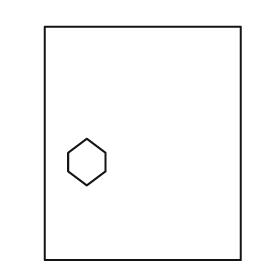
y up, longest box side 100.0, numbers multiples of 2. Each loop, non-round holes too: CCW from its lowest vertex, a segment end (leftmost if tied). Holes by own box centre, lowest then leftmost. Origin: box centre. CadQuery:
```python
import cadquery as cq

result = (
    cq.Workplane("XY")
    .moveTo(-42.0, -50.0)
    .lineTo(42.0, -50.0)
    .lineTo(42.0, 50.0)
    .lineTo(-42.0, 50.0)
    .close()
    .moveTo(-24.0, -18.0)
    .lineTo(-16.0, -12.0)
    .lineTo(-16.0, -4.0)
    .lineTo(-24.0, 2.0)
    .lineTo(-32.0, -4.0)
    .lineTo(-32.0, -12.0)
    .close()
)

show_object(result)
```